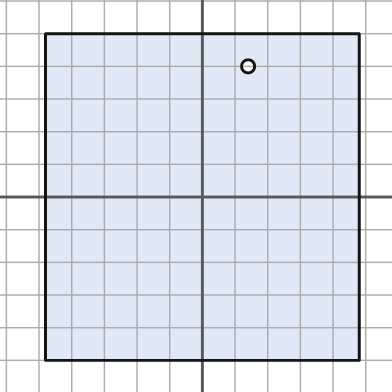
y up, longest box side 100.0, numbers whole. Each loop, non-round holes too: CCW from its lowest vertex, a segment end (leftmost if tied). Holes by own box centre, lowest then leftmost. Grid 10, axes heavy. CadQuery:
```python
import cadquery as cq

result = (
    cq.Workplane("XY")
    .moveTo(-48.0, -50.0)
    .lineTo(48.0, -50.0)
    .lineTo(48.0, 50.0)
    .lineTo(-48.0, 50.0)
    .close()
    .moveTo(14.0, 40.0)
    .circle(2.0)
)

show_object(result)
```